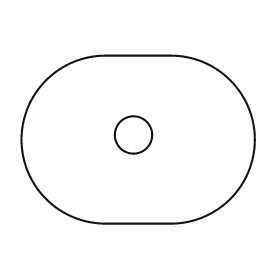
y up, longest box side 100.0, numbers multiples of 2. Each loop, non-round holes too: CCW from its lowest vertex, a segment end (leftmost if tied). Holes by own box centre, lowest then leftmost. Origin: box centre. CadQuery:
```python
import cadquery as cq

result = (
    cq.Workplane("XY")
    .moveTo(-14.0, -36.0)
    .lineTo(14.0, -36.0)
    .threePointArc((50.0, 0.0), (14.0, 36.0))
    .lineTo(-14.0, 36.0)
    .threePointArc((-50.0, 0.0), (-14.0, -36.0))
    .close()
    .moveTo(-2.0, 2.0)
    .circle(8.0)
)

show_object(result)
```